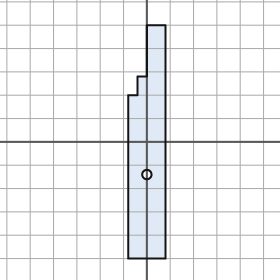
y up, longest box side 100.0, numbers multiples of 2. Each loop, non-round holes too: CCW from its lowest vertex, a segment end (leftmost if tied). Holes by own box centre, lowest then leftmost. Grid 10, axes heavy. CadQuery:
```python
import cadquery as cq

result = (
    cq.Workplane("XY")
    .moveTo(-8.0, -50.0)
    .lineTo(8.0, -50.0)
    .lineTo(8.0, 50.0)
    .lineTo(0.0, 50.0)
    .lineTo(0.0, 28.0)
    .lineTo(-4.0, 28.0)
    .lineTo(-4.0, 20.0)
    .lineTo(-8.0, 20.0)
    .close()
    .moveTo(0.0, -14.0)
    .circle(2.0)
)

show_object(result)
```